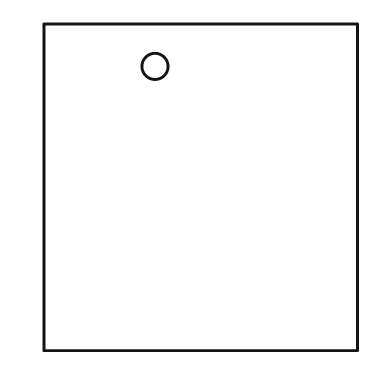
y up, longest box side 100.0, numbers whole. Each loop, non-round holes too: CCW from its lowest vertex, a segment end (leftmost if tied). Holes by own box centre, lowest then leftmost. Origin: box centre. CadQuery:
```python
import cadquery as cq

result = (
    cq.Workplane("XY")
    .moveTo(-48.0, -50.0)
    .lineTo(48.0, -50.0)
    .lineTo(48.0, 50.0)
    .lineTo(-48.0, 50.0)
    .close()
    .moveTo(-14.0, 37.0)
    .circle(4.0)
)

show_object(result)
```